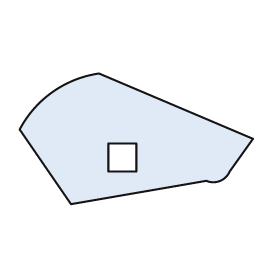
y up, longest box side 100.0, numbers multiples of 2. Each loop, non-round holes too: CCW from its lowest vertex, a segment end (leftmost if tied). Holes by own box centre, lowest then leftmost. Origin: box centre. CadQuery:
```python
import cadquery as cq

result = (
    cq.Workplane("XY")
    .moveTo(-28.0, -28.0)
    .lineTo(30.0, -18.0)
    .threePointArc((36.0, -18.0), (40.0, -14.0))
    .lineTo(50.0, 0.0)
    .lineTo(-16.0, 28.0)
    .threePointArc((-36.0, 20.0), (-50.0, 4.0))
    .close()
    .moveTo(-12.0, -14.0)
    .lineTo(0.0, -14.0)
    .lineTo(0.0, -2.0)
    .lineTo(-12.0, -2.0)
    .close()
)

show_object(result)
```